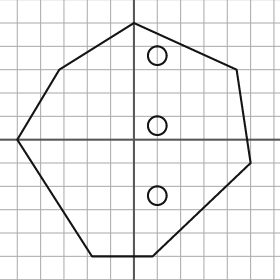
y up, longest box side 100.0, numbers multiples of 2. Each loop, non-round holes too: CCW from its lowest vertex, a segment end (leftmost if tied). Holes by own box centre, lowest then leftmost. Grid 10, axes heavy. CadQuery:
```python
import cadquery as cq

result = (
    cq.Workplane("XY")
    .moveTo(-18.0, -50.0)
    .lineTo(8.0, -50.0)
    .lineTo(50.0, -10.0)
    .lineTo(44.0, 30.0)
    .lineTo(0.0, 50.0)
    .lineTo(-32.0, 30.0)
    .lineTo(-50.0, 0.0)
    .close()
    .moveTo(10.0, -24.0)
    .circle(4.0)
    .moveTo(10.0, 6.0)
    .circle(4.0)
    .moveTo(10.0, 36.0)
    .circle(4.0)
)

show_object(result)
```